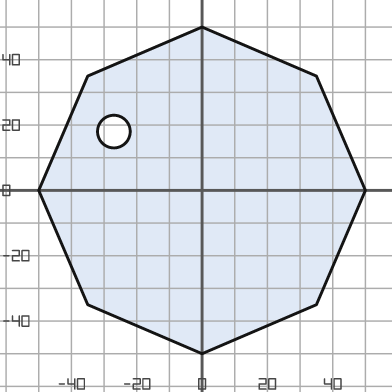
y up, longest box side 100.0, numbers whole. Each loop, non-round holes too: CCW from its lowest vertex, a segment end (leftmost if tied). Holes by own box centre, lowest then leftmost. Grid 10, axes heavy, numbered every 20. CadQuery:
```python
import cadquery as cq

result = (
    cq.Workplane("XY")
    .moveTo(0.0, -50.0)
    .lineTo(35.0, -35.0)
    .lineTo(50.0, 0.0)
    .lineTo(35.0, 35.0)
    .lineTo(0.0, 50.0)
    .lineTo(-35.0, 35.0)
    .lineTo(-50.0, 0.0)
    .lineTo(-35.0, -35.0)
    .close()
    .moveTo(-27.0, 18.0)
    .circle(5.0)
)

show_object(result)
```